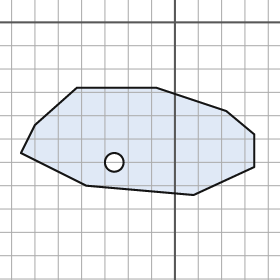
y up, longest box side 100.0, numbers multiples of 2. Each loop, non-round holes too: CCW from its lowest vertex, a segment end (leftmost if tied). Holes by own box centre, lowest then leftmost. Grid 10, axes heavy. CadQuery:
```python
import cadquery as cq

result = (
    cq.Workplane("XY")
    .moveTo(8.0, -74.0)
    .lineTo(34.0, -62.0)
    .lineTo(34.0, -48.0)
    .lineTo(22.0, -38.0)
    .lineTo(-8.0, -28.0)
    .lineTo(-42.0, -28.0)
    .lineTo(-60.0, -44.0)
    .lineTo(-66.0, -56.0)
    .lineTo(-38.0, -70.0)
    .close()
    .moveTo(-26.0, -60.0)
    .circle(4.0)
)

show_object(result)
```